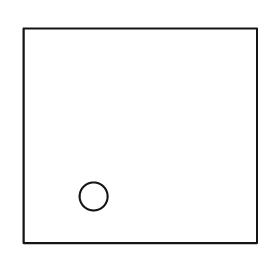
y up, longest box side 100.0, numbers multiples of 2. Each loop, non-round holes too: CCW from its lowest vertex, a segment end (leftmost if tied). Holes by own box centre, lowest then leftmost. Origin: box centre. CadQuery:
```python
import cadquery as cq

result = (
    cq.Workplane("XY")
    .moveTo(-50.0, -46.0)
    .lineTo(50.0, -46.0)
    .lineTo(50.0, 46.0)
    .lineTo(-50.0, 46.0)
    .close()
    .moveTo(-20.0, -26.0)
    .circle(6.0)
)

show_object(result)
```